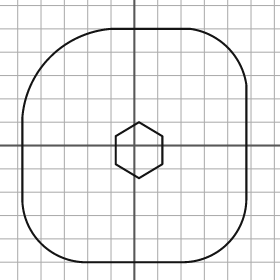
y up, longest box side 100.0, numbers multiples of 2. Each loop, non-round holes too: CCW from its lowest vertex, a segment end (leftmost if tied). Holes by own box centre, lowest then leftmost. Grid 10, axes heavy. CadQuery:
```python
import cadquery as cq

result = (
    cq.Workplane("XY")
    .moveTo(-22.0, -50.0)
    .lineTo(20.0, -50.0)
    .threePointArc((40.0, -42.0), (48.0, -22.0))
    .lineTo(48.0, 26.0)
    .threePointArc((40.0, 42.0), (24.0, 50.0))
    .lineTo(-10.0, 50.0)
    .threePointArc((-36.0, 38.0), (-48.0, 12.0))
    .lineTo(-48.0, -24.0)
    .threePointArc((-40.0, -42.0), (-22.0, -50.0))
    .close()
    .moveTo(2.0, -14.0)
    .lineTo(12.0, -8.0)
    .lineTo(12.0, 4.0)
    .lineTo(2.0, 10.0)
    .lineTo(-8.0, 4.0)
    .lineTo(-8.0, -8.0)
    .close()
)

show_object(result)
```